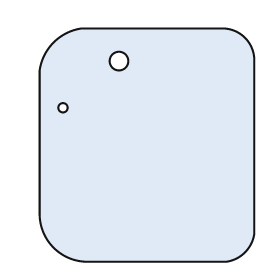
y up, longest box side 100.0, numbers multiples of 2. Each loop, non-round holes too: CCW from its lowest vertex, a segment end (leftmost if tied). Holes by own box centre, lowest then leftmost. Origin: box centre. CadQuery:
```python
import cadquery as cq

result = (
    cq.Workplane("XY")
    .moveTo(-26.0, -50.0)
    .lineTo(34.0, -50.0)
    .threePointArc((42.0, -46.0), (46.0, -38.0))
    .lineTo(46.0, 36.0)
    .threePointArc((42.0, 46.0), (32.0, 50.0))
    .lineTo(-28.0, 50.0)
    .threePointArc((-40.0, 44.0), (-46.0, 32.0))
    .lineTo(-46.0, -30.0)
    .threePointArc((-40.0, -44.0), (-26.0, -50.0))
    .close()
    .moveTo(-36.0, 16.0)
    .circle(2.0)
    .moveTo(-12.0, 36.0)
    .circle(4.0)
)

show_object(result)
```